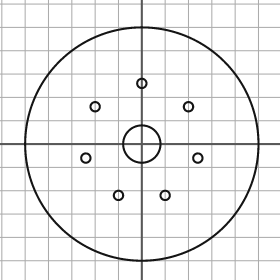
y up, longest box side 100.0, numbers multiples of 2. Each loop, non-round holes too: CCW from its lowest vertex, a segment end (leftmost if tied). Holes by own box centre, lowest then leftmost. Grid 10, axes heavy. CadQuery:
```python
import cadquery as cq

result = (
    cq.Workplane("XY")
    .moveTo(0.0, 0.0)
    .circle(50.0)
    .moveTo(-10.0, -22.0)
    .circle(2.0)
    .moveTo(10.0, -22.0)
    .circle(2.0)
    .moveTo(-24.0, -6.0)
    .circle(2.0)
    .moveTo(24.0, -6.0)
    .circle(2.0)
    .moveTo(0.0, 0.0)
    .circle(8.0)
    .moveTo(-20.0, 16.0)
    .circle(2.0)
    .moveTo(20.0, 16.0)
    .circle(2.0)
    .moveTo(0.0, 26.0)
    .circle(2.0)
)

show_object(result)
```